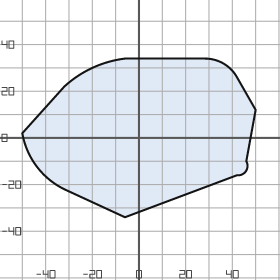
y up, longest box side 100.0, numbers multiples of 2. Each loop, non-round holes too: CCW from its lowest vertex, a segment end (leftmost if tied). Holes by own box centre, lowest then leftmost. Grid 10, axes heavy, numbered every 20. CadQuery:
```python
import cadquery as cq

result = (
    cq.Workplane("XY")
    .moveTo(-6.0, -34.0)
    .lineTo(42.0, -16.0)
    .threePointArc((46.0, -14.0), (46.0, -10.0))
    .lineTo(50.0, 12.0)
    .lineTo(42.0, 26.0)
    .threePointArc((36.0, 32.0), (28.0, 34.0))
    .lineTo(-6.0, 34.0)
    .threePointArc((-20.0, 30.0), (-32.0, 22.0))
    .lineTo(-50.0, 2.0)
    .threePointArc((-44.0, -12.0), (-32.0, -22.0))
    .close()
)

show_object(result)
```